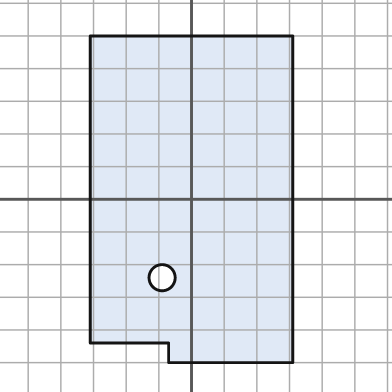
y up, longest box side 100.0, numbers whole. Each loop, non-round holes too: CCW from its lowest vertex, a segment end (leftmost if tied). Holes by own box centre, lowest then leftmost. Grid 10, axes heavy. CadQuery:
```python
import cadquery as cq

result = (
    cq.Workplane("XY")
    .moveTo(-7.0, -50.0)
    .lineTo(31.0, -50.0)
    .lineTo(31.0, 50.0)
    .lineTo(-31.0, 50.0)
    .lineTo(-31.0, -44.0)
    .lineTo(-7.0, -44.0)
    .close()
    .moveTo(-9.0, -24.0)
    .circle(4.0)
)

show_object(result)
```